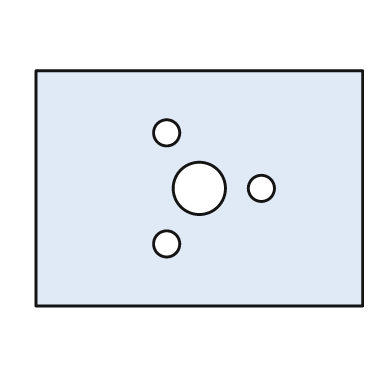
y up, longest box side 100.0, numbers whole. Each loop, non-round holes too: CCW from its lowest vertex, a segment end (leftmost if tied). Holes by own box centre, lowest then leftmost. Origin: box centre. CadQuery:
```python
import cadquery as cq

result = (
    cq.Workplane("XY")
    .moveTo(-50.0, -36.0)
    .lineTo(50.0, -36.0)
    .lineTo(50.0, 36.0)
    .lineTo(-50.0, 36.0)
    .close()
    .moveTo(-10.0, -17.0)
    .circle(4.0)
    .moveTo(0.0, 0.0)
    .circle(8.0)
    .moveTo(19.0, 0.0)
    .circle(4.0)
    .moveTo(-10.0, 17.0)
    .circle(4.0)
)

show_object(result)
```